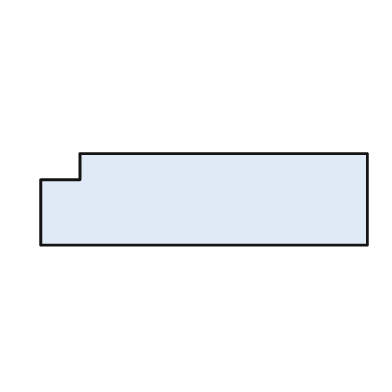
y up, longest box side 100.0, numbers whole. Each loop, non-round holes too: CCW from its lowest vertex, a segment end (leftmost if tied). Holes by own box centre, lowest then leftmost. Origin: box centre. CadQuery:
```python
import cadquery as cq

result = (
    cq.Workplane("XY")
    .moveTo(-50.0, -14.0)
    .lineTo(50.0, -14.0)
    .lineTo(50.0, 14.0)
    .lineTo(-38.0, 14.0)
    .lineTo(-38.0, 6.0)
    .lineTo(-50.0, 6.0)
    .close()
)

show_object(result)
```